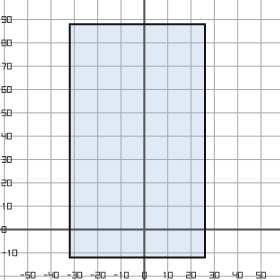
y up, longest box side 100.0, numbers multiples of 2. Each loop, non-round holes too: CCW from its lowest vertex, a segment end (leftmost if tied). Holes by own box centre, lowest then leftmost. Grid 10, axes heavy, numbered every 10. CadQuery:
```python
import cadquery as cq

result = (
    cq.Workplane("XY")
    .moveTo(-32.0, -12.0)
    .lineTo(26.0, -12.0)
    .lineTo(26.0, 88.0)
    .lineTo(-32.0, 88.0)
    .close()
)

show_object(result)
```